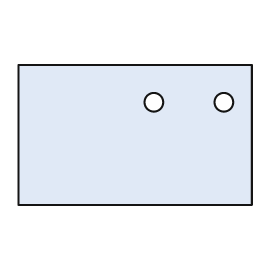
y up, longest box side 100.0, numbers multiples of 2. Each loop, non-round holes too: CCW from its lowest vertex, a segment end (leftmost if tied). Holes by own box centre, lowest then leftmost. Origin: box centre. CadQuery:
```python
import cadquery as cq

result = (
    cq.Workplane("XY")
    .moveTo(-50.0, -30.0)
    .lineTo(50.0, -30.0)
    .lineTo(50.0, 30.0)
    .lineTo(-50.0, 30.0)
    .close()
    .moveTo(8.0, 14.0)
    .circle(4.0)
    .moveTo(38.0, 14.0)
    .circle(4.0)
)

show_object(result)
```